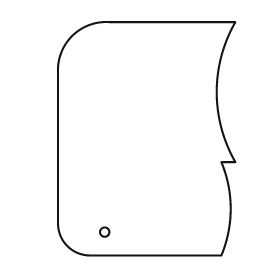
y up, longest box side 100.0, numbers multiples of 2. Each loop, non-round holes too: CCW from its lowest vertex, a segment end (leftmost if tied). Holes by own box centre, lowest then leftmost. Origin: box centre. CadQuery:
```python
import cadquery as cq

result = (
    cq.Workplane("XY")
    .moveTo(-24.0, -50.0)
    .lineTo(32.0, -50.0)
    .threePointArc((36.0, -30.0), (32.0, -10.0))
    .lineTo(38.0, -10.0)
    .threePointArc((30.0, 20.0), (38.0, 50.0))
    .lineTo(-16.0, 50.0)
    .threePointArc((-32.0, 44.0), (-38.0, 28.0))
    .lineTo(-38.0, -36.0)
    .threePointArc((-34.0, -46.0), (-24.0, -50.0))
    .close()
    .moveTo(-18.0, -40.0)
    .circle(2.0)
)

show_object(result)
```